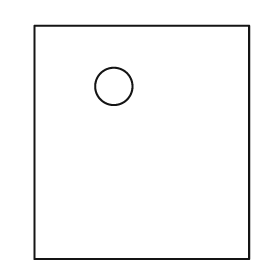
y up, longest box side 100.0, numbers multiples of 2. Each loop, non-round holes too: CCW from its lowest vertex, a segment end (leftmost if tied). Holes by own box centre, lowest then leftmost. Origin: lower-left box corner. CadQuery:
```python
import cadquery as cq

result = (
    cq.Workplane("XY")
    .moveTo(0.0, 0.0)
    .lineTo(92.0, 0.0)
    .lineTo(92.0, 100.0)
    .lineTo(0.0, 100.0)
    .close()
    .moveTo(34.0, 74.0)
    .circle(8.0)
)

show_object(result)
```